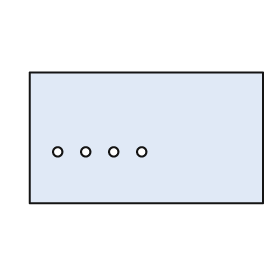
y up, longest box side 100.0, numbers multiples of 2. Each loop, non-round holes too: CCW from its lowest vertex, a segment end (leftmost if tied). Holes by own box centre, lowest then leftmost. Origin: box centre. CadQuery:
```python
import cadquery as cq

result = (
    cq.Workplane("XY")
    .moveTo(-50.0, -28.0)
    .lineTo(50.0, -28.0)
    .lineTo(50.0, 28.0)
    .lineTo(-50.0, 28.0)
    .close()
    .moveTo(-38.0, -6.0)
    .circle(2.0)
    .moveTo(-26.0, -6.0)
    .circle(2.0)
    .moveTo(-14.0, -6.0)
    .circle(2.0)
    .moveTo(-2.0, -6.0)
    .circle(2.0)
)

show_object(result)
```